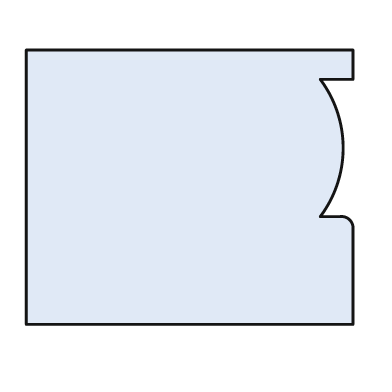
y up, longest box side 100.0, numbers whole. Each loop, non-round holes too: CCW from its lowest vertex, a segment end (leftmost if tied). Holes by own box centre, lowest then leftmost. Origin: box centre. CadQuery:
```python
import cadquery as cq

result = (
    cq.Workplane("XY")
    .moveTo(-50.0, -42.0)
    .lineTo(50.0, -42.0)
    .lineTo(50.0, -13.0)
    .threePointArc((49.0, -10.0), (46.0, -9.0))
    .lineTo(40.0, -9.0)
    .threePointArc((47.0, 12.0), (40.0, 33.0))
    .lineTo(50.0, 33.0)
    .lineTo(50.0, 42.0)
    .lineTo(-50.0, 42.0)
    .close()
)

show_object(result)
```